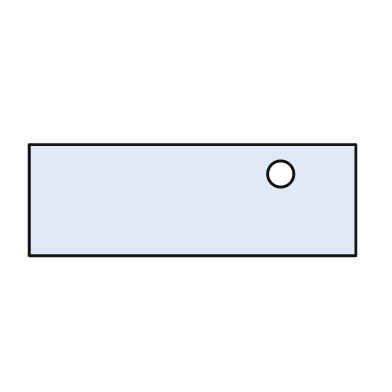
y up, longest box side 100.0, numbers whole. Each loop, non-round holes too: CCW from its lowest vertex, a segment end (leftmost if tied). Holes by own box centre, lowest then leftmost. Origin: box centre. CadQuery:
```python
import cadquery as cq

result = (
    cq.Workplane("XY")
    .moveTo(-50.0, -17.0)
    .lineTo(50.0, -17.0)
    .lineTo(50.0, 17.0)
    .lineTo(-50.0, 17.0)
    .close()
    .moveTo(27.0, 8.0)
    .circle(4.0)
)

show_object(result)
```